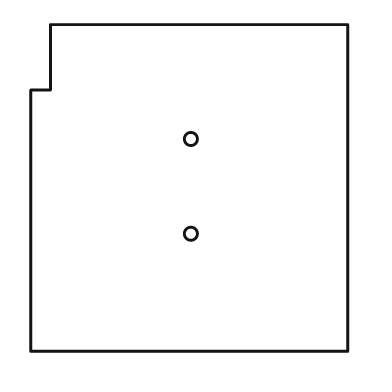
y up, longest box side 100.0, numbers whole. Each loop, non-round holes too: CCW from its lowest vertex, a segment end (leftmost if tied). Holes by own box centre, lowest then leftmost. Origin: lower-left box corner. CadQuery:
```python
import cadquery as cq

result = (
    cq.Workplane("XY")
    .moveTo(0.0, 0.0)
    .lineTo(97.0, 0.0)
    .lineTo(97.0, 100.0)
    .lineTo(6.0, 100.0)
    .lineTo(6.0, 80.0)
    .lineTo(0.0, 80.0)
    .close()
    .moveTo(49.0, 36.0)
    .circle(2.0)
    .moveTo(49.0, 65.0)
    .circle(2.0)
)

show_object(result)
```